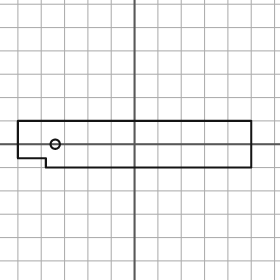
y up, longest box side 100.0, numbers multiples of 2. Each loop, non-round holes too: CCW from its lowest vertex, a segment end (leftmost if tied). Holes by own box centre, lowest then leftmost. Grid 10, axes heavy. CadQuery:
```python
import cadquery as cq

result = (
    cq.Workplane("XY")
    .moveTo(-38.0, -10.0)
    .lineTo(50.0, -10.0)
    .lineTo(50.0, 10.0)
    .lineTo(-50.0, 10.0)
    .lineTo(-50.0, -6.0)
    .lineTo(-38.0, -6.0)
    .close()
    .moveTo(-34.0, 0.0)
    .circle(2.0)
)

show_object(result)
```